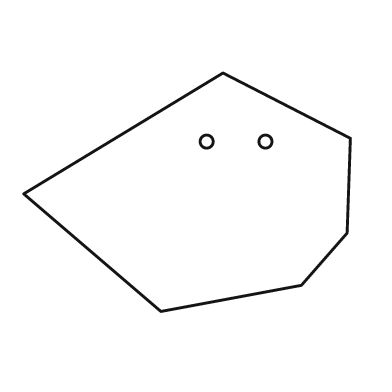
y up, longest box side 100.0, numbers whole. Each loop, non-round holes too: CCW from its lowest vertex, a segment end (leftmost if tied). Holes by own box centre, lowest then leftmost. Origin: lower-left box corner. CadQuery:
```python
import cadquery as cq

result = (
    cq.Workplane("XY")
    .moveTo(42.0, 0.0)
    .lineTo(85.0, 8.0)
    .lineTo(99.0, 24.0)
    .lineTo(100.0, 53.0)
    .lineTo(61.0, 73.0)
    .lineTo(0.0, 36.0)
    .close()
    .moveTo(56.0, 52.0)
    .circle(2.0)
    .moveTo(74.0, 52.0)
    .circle(2.0)
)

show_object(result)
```